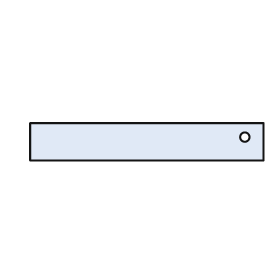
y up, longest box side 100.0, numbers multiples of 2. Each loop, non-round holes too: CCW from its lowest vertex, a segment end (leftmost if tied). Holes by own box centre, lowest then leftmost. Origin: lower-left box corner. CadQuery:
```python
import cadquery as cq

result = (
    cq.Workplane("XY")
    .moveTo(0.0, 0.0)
    .lineTo(100.0, 0.0)
    .lineTo(100.0, 16.0)
    .lineTo(0.0, 16.0)
    .close()
    .moveTo(92.0, 10.0)
    .circle(2.0)
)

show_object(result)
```